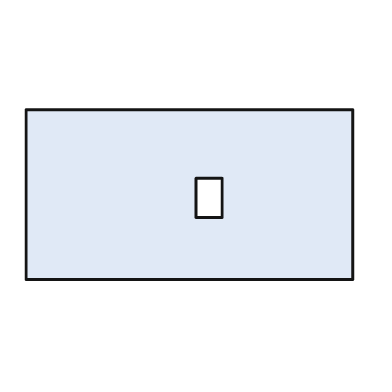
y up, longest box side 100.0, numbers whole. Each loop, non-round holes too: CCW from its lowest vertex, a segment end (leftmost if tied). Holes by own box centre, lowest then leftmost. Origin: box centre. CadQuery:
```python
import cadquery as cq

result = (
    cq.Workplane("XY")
    .moveTo(-50.0, -26.0)
    .lineTo(50.0, -26.0)
    .lineTo(50.0, 26.0)
    .lineTo(-50.0, 26.0)
    .close()
    .moveTo(2.0, -7.0)
    .lineTo(10.0, -7.0)
    .lineTo(10.0, 5.0)
    .lineTo(2.0, 5.0)
    .close()
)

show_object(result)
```